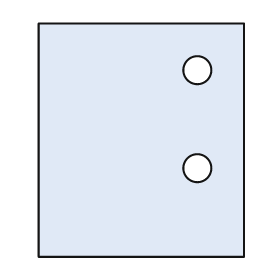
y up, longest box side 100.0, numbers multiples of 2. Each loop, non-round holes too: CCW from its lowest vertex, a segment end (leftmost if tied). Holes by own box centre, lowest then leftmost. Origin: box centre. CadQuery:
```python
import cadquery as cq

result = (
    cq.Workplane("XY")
    .moveTo(-44.0, -50.0)
    .lineTo(44.0, -50.0)
    .lineTo(44.0, 50.0)
    .lineTo(-44.0, 50.0)
    .close()
    .moveTo(24.0, -12.0)
    .circle(6.0)
    .moveTo(24.0, 30.0)
    .circle(6.0)
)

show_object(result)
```